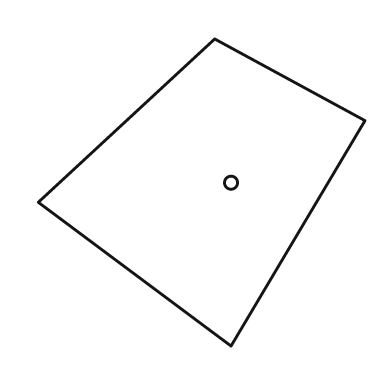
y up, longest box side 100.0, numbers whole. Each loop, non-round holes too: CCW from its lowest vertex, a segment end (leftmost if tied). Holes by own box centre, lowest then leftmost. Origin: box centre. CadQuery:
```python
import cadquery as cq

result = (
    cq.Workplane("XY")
    .moveTo(9.0, -47.0)
    .lineTo(50.0, 22.0)
    .lineTo(4.0, 47.0)
    .lineTo(-50.0, -3.0)
    .close()
    .moveTo(9.0, 3.0)
    .circle(2.0)
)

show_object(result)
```